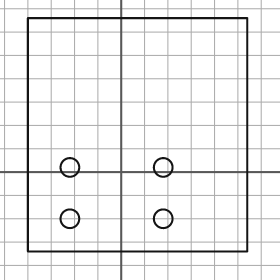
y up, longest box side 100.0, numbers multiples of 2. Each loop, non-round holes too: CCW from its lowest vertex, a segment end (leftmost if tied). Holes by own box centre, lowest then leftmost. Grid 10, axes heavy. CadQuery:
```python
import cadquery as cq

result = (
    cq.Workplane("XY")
    .moveTo(-40.0, -34.0)
    .lineTo(54.0, -34.0)
    .lineTo(54.0, 66.0)
    .lineTo(-40.0, 66.0)
    .close()
    .moveTo(-22.0, -20.0)
    .circle(4.0)
    .moveTo(18.0, -20.0)
    .circle(4.0)
    .moveTo(-22.0, 2.0)
    .circle(4.0)
    .moveTo(18.0, 2.0)
    .circle(4.0)
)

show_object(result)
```